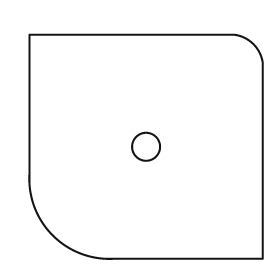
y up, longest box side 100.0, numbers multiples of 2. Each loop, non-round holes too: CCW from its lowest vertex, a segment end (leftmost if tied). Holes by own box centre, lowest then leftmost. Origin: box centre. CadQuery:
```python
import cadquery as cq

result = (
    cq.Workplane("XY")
    .moveTo(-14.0, -48.0)
    .lineTo(50.0, -48.0)
    .lineTo(50.0, 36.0)
    .threePointArc((46.0, 44.0), (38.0, 48.0))
    .lineTo(-50.0, 48.0)
    .lineTo(-50.0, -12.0)
    .threePointArc((-40.0, -38.0), (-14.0, -48.0))
    .close()
    .moveTo(0.0, 0.0)
    .circle(6.0)
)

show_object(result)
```